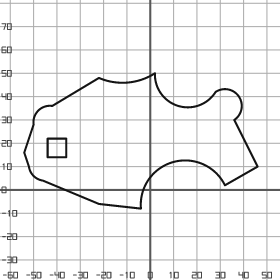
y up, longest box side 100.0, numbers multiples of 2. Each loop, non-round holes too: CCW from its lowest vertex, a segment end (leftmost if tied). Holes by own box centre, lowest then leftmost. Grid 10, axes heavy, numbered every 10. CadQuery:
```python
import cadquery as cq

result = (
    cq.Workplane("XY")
    .moveTo(-4.0, -8.0)
    .threePointArc((10.0, 12.0), (32.0, 2.0))
    .lineTo(46.0, 10.0)
    .lineTo(36.0, 30.0)
    .threePointArc((38.0, 40.0), (28.0, 42.0))
    .threePointArc((12.0, 36.0), (2.0, 50.0))
    .threePointArc((-10.0, 46.0), (-22.0, 48.0))
    .lineTo(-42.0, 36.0)
    .threePointArc((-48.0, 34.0), (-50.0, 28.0))
    .lineTo(-54.0, 16.0)
    .lineTo(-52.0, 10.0)
    .threePointArc((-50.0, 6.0), (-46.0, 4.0))
    .lineTo(-22.0, -6.0)
    .close()
    .moveTo(-44.0, 14.0)
    .lineTo(-36.0, 14.0)
    .lineTo(-36.0, 22.0)
    .lineTo(-44.0, 22.0)
    .close()
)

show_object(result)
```